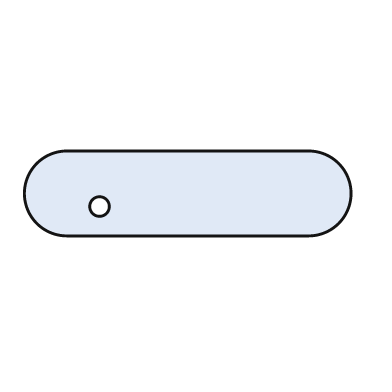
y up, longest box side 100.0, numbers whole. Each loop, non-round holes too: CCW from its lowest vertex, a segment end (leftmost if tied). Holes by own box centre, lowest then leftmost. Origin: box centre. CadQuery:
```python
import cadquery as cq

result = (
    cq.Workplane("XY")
    .moveTo(-37.0, -13.0)
    .lineTo(37.0, -13.0)
    .threePointArc((50.0, 0.0), (37.0, 13.0))
    .lineTo(-37.0, 13.0)
    .threePointArc((-50.0, 0.0), (-37.0, -13.0))
    .close()
    .moveTo(-27.0, -4.0)
    .circle(3.0)
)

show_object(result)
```